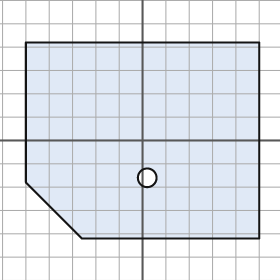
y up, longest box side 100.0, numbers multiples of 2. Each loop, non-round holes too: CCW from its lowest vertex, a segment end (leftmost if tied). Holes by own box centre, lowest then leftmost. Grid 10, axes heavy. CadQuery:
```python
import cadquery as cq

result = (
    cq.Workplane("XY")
    .moveTo(-26.0, -42.0)
    .lineTo(50.0, -42.0)
    .lineTo(50.0, 42.0)
    .lineTo(-50.0, 42.0)
    .lineTo(-50.0, -18.0)
    .close()
    .moveTo(2.0, -16.0)
    .circle(4.0)
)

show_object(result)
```